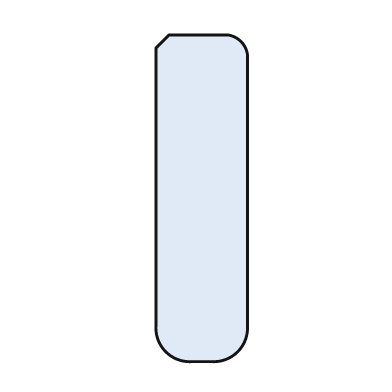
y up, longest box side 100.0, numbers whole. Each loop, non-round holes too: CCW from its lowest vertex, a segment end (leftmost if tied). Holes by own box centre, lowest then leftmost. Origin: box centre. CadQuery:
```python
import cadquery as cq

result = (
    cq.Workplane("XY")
    .moveTo(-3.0, -50.0)
    .lineTo(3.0, -50.0)
    .threePointArc((11.0, -47.0), (14.0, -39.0))
    .lineTo(14.0, 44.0)
    .threePointArc((12.0, 48.0), (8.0, 50.0))
    .lineTo(-10.0, 50.0)
    .lineTo(-14.0, 46.0)
    .lineTo(-14.0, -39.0)
    .threePointArc((-11.0, -47.0), (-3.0, -50.0))
    .close()
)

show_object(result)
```